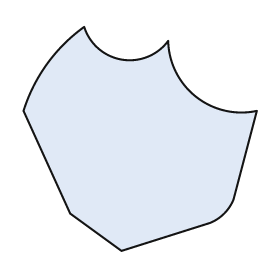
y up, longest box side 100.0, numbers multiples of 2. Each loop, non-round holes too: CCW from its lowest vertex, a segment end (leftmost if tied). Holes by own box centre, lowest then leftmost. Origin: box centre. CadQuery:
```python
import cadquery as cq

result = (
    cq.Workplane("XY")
    .moveTo(-8.0, -48.0)
    .lineTo(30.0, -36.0)
    .threePointArc((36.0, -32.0), (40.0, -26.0))
    .lineTo(50.0, 12.0)
    .threePointArc((24.0, 18.0), (12.0, 42.0))
    .threePointArc((-8.0, 34.0), (-24.0, 48.0))
    .threePointArc((-40.0, 32.0), (-50.0, 12.0))
    .lineTo(-30.0, -32.0)
    .close()
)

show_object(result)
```